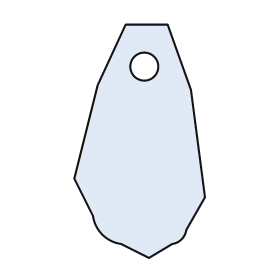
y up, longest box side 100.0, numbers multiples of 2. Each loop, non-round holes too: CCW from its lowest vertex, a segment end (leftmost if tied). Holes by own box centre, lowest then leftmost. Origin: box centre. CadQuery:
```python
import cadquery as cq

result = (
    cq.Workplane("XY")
    .moveTo(4.0, -50.0)
    .lineTo(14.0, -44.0)
    .threePointArc((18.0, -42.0), (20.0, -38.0))
    .lineTo(28.0, -24.0)
    .lineTo(22.0, 22.0)
    .lineTo(12.0, 50.0)
    .lineTo(-6.0, 50.0)
    .lineTo(-18.0, 24.0)
    .lineTo(-28.0, -16.0)
    .lineTo(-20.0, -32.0)
    .threePointArc((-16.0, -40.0), (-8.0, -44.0))
    .close()
    .moveTo(2.0, 32.0)
    .circle(6.0)
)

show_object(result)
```